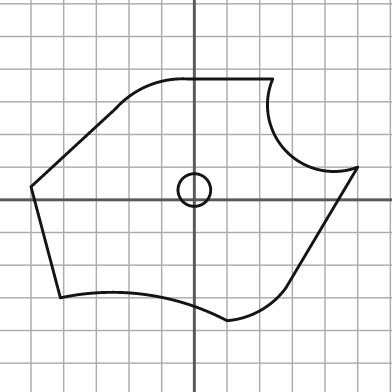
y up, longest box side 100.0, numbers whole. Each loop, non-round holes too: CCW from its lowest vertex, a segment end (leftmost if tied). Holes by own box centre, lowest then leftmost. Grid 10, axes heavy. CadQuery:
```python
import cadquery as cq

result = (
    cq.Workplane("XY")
    .moveTo(10.0, -37.0)
    .threePointArc((20.0, -34.0), (28.0, -27.0))
    .lineTo(50.0, 10.0)
    .threePointArc((28.0, 15.0), (24.0, 37.0))
    .lineTo(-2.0, 37.0)
    .threePointArc((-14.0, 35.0), (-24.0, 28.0))
    .lineTo(-50.0, 4.0)
    .lineTo(-41.0, -30.0)
    .threePointArc((-15.0, -29.0), (10.0, -37.0))
    .close()
    .moveTo(0.0, 3.0)
    .circle(5.0)
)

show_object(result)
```